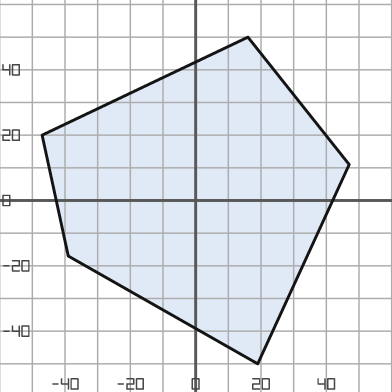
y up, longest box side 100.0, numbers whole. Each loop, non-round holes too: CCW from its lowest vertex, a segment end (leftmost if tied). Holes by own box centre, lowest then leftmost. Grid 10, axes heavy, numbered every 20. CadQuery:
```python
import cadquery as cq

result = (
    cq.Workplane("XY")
    .moveTo(19.0, -50.0)
    .lineTo(47.0, 11.0)
    .lineTo(16.0, 50.0)
    .lineTo(-47.0, 20.0)
    .lineTo(-39.0, -17.0)
    .close()
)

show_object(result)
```